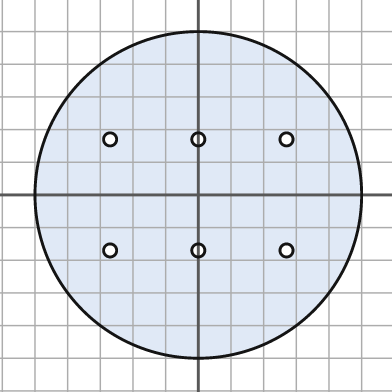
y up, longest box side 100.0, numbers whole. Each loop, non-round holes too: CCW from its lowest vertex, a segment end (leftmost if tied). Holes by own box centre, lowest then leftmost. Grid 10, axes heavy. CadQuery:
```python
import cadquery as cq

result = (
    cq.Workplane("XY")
    .moveTo(0.0, 0.0)
    .circle(50.0)
    .moveTo(-27.0, -17.0)
    .circle(2.0)
    .moveTo(0.0, -17.0)
    .circle(2.0)
    .moveTo(27.0, -17.0)
    .circle(2.0)
    .moveTo(-27.0, 17.0)
    .circle(2.0)
    .moveTo(0.0, 17.0)
    .circle(2.0)
    .moveTo(27.0, 17.0)
    .circle(2.0)
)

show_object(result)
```